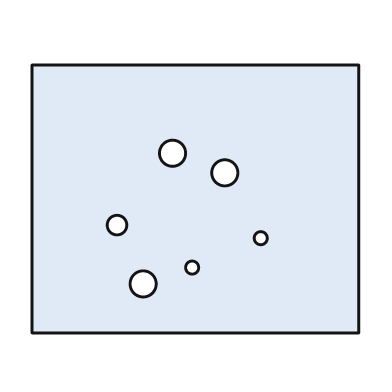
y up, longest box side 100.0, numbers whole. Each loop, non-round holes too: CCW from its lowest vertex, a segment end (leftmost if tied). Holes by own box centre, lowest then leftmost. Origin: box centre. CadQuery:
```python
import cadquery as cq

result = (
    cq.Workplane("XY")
    .moveTo(-50.0, -41.0)
    .lineTo(50.0, -41.0)
    .lineTo(50.0, 41.0)
    .lineTo(-50.0, 41.0)
    .close()
    .moveTo(-16.0, -26.0)
    .circle(4.0)
    .moveTo(-1.0, -21.0)
    .circle(2.0)
    .moveTo(20.0, -12.0)
    .circle(2.0)
    .moveTo(-24.0, -8.0)
    .circle(3.0)
    .moveTo(9.0, 8.0)
    .circle(4.0)
    .moveTo(-7.0, 14.0)
    .circle(4.0)
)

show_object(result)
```